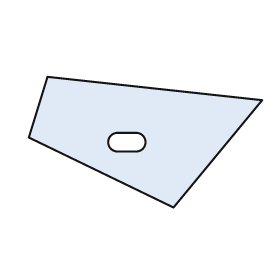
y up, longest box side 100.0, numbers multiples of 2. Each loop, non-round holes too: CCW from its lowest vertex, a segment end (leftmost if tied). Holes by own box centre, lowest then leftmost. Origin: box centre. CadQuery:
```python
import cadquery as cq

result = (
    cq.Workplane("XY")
    .moveTo(12.0, -28.0)
    .lineTo(50.0, 18.0)
    .lineTo(-42.0, 28.0)
    .lineTo(-50.0, 2.0)
    .close()
    .moveTo(-12.0, -4.0)
    .lineTo(-4.0, -4.0)
    .threePointArc((0.0, 0.0), (-4.0, 4.0))
    .lineTo(-12.0, 4.0)
    .threePointArc((-16.0, 0.0), (-12.0, -4.0))
    .close()
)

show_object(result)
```